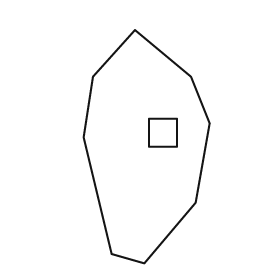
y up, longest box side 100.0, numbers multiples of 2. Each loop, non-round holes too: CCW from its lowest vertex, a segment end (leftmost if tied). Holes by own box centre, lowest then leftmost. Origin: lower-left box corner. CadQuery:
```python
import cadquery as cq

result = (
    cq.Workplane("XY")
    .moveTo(26.0, 0.0)
    .lineTo(48.0, 26.0)
    .lineTo(54.0, 60.0)
    .lineTo(46.0, 80.0)
    .lineTo(22.0, 100.0)
    .lineTo(4.0, 80.0)
    .lineTo(0.0, 54.0)
    .lineTo(12.0, 4.0)
    .close()
    .moveTo(28.0, 50.0)
    .lineTo(40.0, 50.0)
    .lineTo(40.0, 62.0)
    .lineTo(28.0, 62.0)
    .close()
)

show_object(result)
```